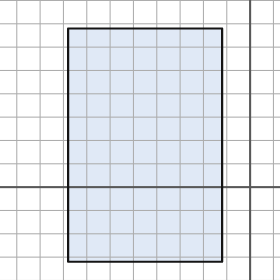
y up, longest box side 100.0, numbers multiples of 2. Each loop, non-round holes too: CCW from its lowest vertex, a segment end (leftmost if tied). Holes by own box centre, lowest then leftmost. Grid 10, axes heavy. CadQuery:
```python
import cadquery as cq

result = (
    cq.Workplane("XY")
    .moveTo(-78.0, -32.0)
    .lineTo(-12.0, -32.0)
    .lineTo(-12.0, 68.0)
    .lineTo(-78.0, 68.0)
    .close()
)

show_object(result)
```